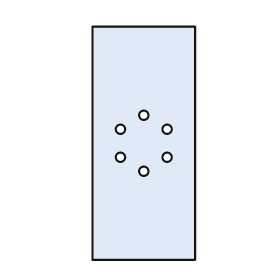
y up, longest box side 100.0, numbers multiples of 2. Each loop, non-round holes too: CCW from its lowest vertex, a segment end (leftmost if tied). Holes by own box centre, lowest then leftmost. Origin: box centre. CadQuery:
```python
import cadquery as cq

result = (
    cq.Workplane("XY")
    .moveTo(-22.0, -50.0)
    .lineTo(22.0, -50.0)
    .lineTo(22.0, 50.0)
    .lineTo(-22.0, 50.0)
    .close()
    .moveTo(0.0, -12.0)
    .circle(2.0)
    .moveTo(-10.0, -6.0)
    .circle(2.0)
    .moveTo(10.0, -6.0)
    .circle(2.0)
    .moveTo(-10.0, 6.0)
    .circle(2.0)
    .moveTo(10.0, 6.0)
    .circle(2.0)
    .moveTo(0.0, 12.0)
    .circle(2.0)
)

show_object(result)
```